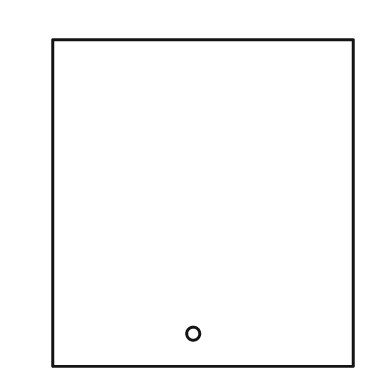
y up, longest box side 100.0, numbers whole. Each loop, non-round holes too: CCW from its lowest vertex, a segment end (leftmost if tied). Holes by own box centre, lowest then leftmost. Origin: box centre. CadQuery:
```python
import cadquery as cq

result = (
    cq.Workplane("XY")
    .moveTo(-46.0, -50.0)
    .lineTo(46.0, -50.0)
    .lineTo(46.0, 50.0)
    .lineTo(-46.0, 50.0)
    .close()
    .moveTo(-3.0, -40.0)
    .circle(2.0)
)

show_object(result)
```